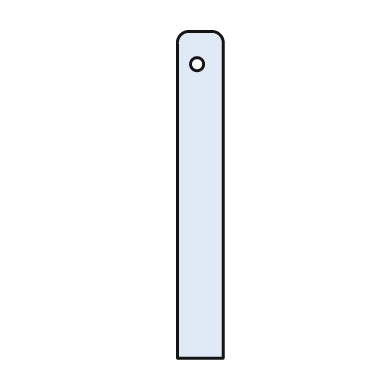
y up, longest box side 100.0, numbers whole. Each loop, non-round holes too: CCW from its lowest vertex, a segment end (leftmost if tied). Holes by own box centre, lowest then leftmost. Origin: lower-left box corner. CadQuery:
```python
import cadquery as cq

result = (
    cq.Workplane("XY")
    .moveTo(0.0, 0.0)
    .lineTo(14.0, 0.0)
    .lineTo(14.0, 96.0)
    .threePointArc((13.0, 99.0), (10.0, 100.0))
    .lineTo(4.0, 100.0)
    .threePointArc((1.0, 99.0), (0.0, 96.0))
    .close()
    .moveTo(6.0, 90.0)
    .circle(2.0)
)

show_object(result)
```